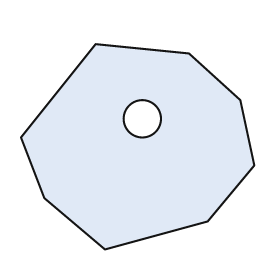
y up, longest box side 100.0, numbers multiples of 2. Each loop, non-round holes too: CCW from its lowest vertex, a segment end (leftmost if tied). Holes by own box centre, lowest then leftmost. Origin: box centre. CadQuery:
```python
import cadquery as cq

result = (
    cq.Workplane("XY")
    .moveTo(-14.0, -44.0)
    .lineTo(30.0, -32.0)
    .lineTo(50.0, -8.0)
    .lineTo(44.0, 20.0)
    .lineTo(22.0, 40.0)
    .lineTo(-18.0, 44.0)
    .lineTo(-50.0, 4.0)
    .lineTo(-40.0, -22.0)
    .close()
    .moveTo(2.0, 12.0)
    .circle(8.0)
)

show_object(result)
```